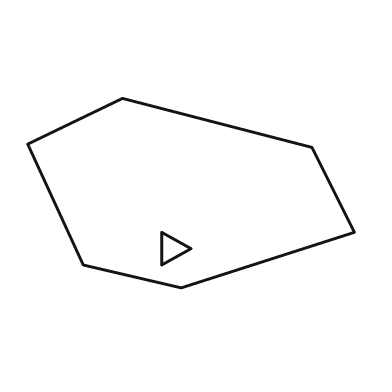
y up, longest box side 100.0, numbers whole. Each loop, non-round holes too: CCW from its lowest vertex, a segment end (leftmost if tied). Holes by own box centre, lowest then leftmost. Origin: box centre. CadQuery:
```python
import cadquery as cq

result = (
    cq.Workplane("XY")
    .moveTo(-3.0, -29.0)
    .lineTo(50.0, -12.0)
    .lineTo(37.0, 14.0)
    .lineTo(-21.0, 29.0)
    .lineTo(-50.0, 15.0)
    .lineTo(-33.0, -22.0)
    .close()
    .moveTo(-9.0, -22.0)
    .lineTo(0.0, -17.0)
    .lineTo(-9.0, -12.0)
    .close()
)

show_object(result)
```